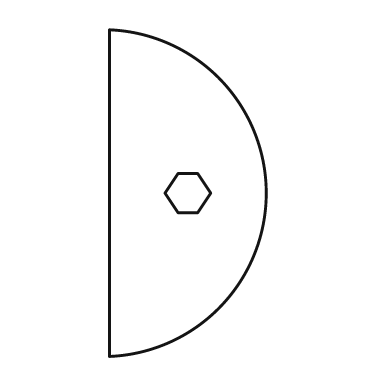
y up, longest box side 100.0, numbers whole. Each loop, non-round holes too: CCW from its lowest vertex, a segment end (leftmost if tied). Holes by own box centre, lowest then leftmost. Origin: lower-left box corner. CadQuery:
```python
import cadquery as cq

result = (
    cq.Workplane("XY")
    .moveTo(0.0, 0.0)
    .threePointArc((48.0, 50.0), (0.0, 100.0))
    .close()
    .moveTo(21.0, 44.0)
    .lineTo(27.0, 44.0)
    .lineTo(31.0, 50.0)
    .lineTo(27.0, 56.0)
    .lineTo(21.0, 56.0)
    .lineTo(17.0, 50.0)
    .close()
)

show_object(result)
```